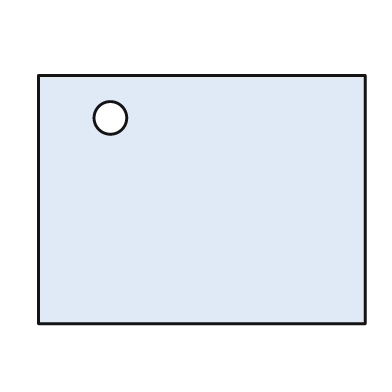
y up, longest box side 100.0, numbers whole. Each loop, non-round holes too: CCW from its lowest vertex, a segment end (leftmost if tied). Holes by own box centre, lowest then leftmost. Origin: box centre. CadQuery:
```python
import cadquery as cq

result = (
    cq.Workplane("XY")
    .moveTo(-50.0, -38.0)
    .lineTo(50.0, -38.0)
    .lineTo(50.0, 38.0)
    .lineTo(-50.0, 38.0)
    .close()
    .moveTo(-28.0, 25.0)
    .circle(5.0)
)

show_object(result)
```